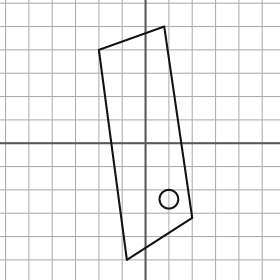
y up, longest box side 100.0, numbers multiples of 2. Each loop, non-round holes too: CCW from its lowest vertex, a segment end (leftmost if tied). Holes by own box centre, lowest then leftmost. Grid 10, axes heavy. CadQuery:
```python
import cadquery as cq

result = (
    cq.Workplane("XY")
    .moveTo(-8.0, -50.0)
    .lineTo(20.0, -32.0)
    .lineTo(8.0, 50.0)
    .lineTo(-20.0, 40.0)
    .close()
    .moveTo(10.0, -24.0)
    .circle(4.0)
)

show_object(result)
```